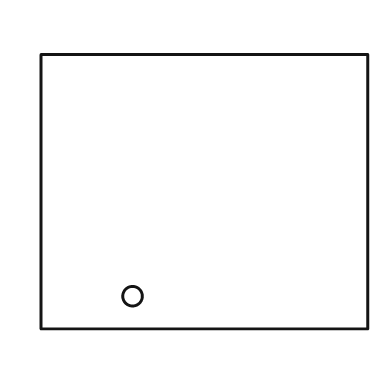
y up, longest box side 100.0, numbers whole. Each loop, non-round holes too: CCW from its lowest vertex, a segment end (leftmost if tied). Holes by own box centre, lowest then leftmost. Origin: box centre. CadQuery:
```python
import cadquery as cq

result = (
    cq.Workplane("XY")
    .moveTo(-50.0, -42.0)
    .lineTo(50.0, -42.0)
    .lineTo(50.0, 42.0)
    .lineTo(-50.0, 42.0)
    .close()
    .moveTo(-22.0, -32.0)
    .circle(3.0)
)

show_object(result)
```